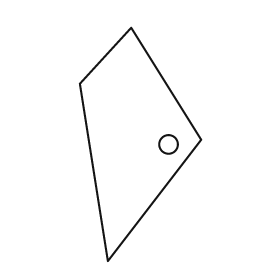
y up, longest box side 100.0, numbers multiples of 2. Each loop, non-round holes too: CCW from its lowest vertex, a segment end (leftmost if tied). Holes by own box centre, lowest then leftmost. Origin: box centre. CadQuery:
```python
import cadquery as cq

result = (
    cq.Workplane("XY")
    .moveTo(-14.0, -50.0)
    .lineTo(26.0, 2.0)
    .lineTo(-4.0, 50.0)
    .lineTo(-26.0, 26.0)
    .close()
    .moveTo(12.0, 0.0)
    .circle(4.0)
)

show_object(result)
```